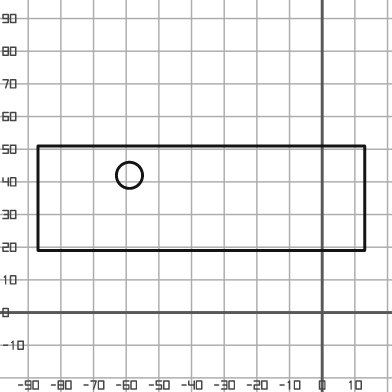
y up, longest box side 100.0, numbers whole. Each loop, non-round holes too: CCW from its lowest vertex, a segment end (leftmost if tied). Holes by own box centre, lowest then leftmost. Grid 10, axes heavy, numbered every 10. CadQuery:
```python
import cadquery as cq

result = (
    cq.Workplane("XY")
    .moveTo(-87.0, 19.0)
    .lineTo(13.0, 19.0)
    .lineTo(13.0, 51.0)
    .lineTo(-87.0, 51.0)
    .close()
    .moveTo(-59.0, 42.0)
    .circle(4.0)
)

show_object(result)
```